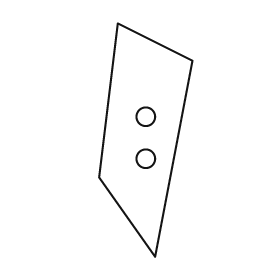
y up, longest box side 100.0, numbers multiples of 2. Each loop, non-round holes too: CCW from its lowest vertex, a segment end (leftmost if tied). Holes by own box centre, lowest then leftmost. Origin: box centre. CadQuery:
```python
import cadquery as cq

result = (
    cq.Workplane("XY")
    .moveTo(4.0, -50.0)
    .lineTo(20.0, 34.0)
    .lineTo(-12.0, 50.0)
    .lineTo(-20.0, -16.0)
    .close()
    .moveTo(0.0, -8.0)
    .circle(4.0)
    .moveTo(0.0, 10.0)
    .circle(4.0)
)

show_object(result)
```